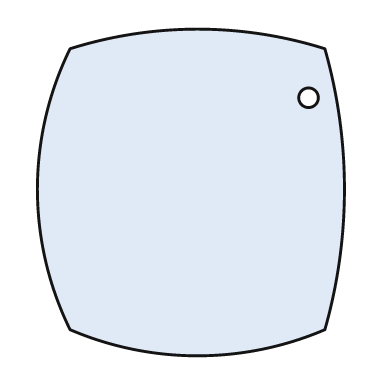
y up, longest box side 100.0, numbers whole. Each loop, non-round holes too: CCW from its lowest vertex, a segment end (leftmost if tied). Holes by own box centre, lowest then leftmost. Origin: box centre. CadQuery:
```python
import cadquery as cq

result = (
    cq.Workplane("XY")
    .moveTo(-37.0, -42.0)
    .threePointArc((2.0, -50.0), (41.0, -42.0))
    .threePointArc((47.0, 1.0), (41.0, 44.0))
    .threePointArc((2.0, 50.0), (-37.0, 44.0))
    .threePointArc((-47.0, 1.0), (-37.0, -42.0))
    .close()
    .moveTo(36.0, 29.0)
    .circle(3.0)
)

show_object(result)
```